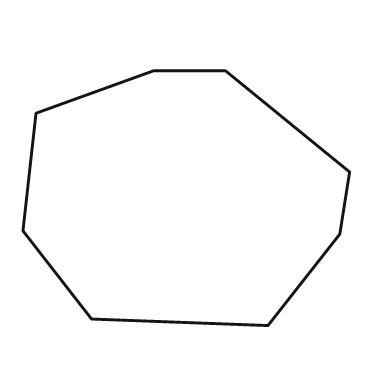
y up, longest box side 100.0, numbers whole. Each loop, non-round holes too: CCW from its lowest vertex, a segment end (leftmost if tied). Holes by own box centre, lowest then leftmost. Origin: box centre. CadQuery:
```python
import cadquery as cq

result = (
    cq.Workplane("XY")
    .moveTo(25.0, -39.0)
    .lineTo(47.0, -11.0)
    .lineTo(50.0, 8.0)
    .lineTo(12.0, 39.0)
    .lineTo(-10.0, 39.0)
    .lineTo(-46.0, 26.0)
    .lineTo(-50.0, -10.0)
    .lineTo(-29.0, -37.0)
    .close()
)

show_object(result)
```